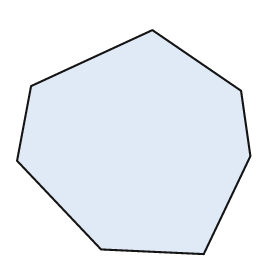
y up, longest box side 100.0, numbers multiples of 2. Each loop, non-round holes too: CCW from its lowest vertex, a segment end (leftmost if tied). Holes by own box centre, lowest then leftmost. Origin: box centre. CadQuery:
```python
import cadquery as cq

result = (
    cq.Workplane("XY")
    .moveTo(30.0, -48.0)
    .lineTo(50.0, -6.0)
    .lineTo(46.0, 22.0)
    .lineTo(8.0, 48.0)
    .lineTo(-44.0, 24.0)
    .lineTo(-50.0, -8.0)
    .lineTo(-14.0, -46.0)
    .close()
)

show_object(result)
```